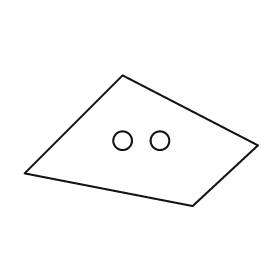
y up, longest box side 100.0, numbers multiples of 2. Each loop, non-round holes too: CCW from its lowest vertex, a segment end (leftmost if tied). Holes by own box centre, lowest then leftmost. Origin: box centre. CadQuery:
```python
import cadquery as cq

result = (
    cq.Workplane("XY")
    .moveTo(22.0, -28.0)
    .lineTo(50.0, -2.0)
    .lineTo(-8.0, 28.0)
    .lineTo(-50.0, -14.0)
    .close()
    .moveTo(-8.0, 0.0)
    .circle(4.0)
    .moveTo(8.0, 0.0)
    .circle(4.0)
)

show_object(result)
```